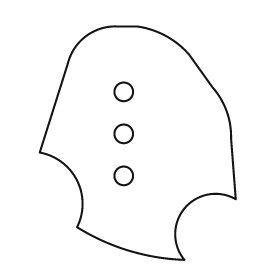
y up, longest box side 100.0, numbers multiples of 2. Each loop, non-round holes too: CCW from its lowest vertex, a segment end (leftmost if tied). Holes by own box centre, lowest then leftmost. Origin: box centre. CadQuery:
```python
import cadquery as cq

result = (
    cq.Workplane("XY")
    .moveTo(20.0, -50.0)
    .threePointArc((20.0, -28.0), (42.0, -24.0))
    .lineTo(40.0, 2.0)
    .threePointArc((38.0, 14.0), (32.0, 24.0))
    .lineTo(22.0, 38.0)
    .threePointArc((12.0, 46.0), (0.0, 50.0))
    .lineTo(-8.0, 50.0)
    .threePointArc((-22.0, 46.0), (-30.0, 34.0))
    .lineTo(-42.0, -4.0)
    .threePointArc((-26.0, -16.0), (-26.0, -36.0))
    .threePointArc((-4.0, -46.0), (20.0, -50.0))
    .close()
    .moveTo(-6.0, -14.0)
    .circle(4.0)
    .moveTo(-6.0, 4.0)
    .circle(4.0)
    .moveTo(-6.0, 22.0)
    .circle(4.0)
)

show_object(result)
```